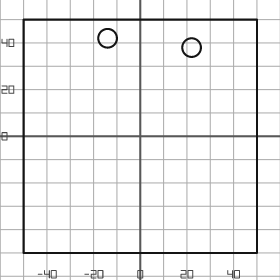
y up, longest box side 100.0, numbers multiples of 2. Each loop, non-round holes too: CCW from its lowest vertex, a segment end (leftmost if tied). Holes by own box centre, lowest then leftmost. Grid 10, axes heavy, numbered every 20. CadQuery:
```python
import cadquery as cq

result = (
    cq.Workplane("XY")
    .moveTo(-50.0, -50.0)
    .lineTo(50.0, -50.0)
    .lineTo(50.0, 50.0)
    .lineTo(-50.0, 50.0)
    .close()
    .moveTo(22.0, 38.0)
    .circle(4.0)
    .moveTo(-14.0, 42.0)
    .circle(4.0)
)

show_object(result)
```